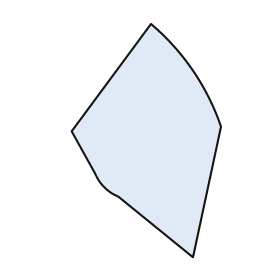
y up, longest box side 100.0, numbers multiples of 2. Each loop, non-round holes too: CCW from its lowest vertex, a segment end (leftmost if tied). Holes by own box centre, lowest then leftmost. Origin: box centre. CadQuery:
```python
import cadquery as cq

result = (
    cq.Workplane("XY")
    .moveTo(20.0, -50.0)
    .lineTo(32.0, 6.0)
    .threePointArc((20.0, 30.0), (2.0, 50.0))
    .lineTo(-32.0, 4.0)
    .lineTo(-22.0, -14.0)
    .threePointArc((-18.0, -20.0), (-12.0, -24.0))
    .close()
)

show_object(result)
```